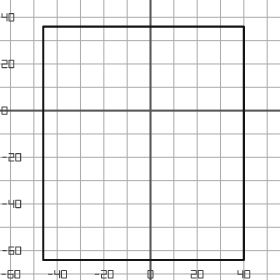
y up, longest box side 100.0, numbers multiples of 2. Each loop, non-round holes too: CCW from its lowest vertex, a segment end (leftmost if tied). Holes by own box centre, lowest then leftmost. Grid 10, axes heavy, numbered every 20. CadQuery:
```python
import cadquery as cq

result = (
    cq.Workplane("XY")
    .moveTo(-46.0, -64.0)
    .lineTo(40.0, -64.0)
    .lineTo(40.0, 36.0)
    .lineTo(-46.0, 36.0)
    .close()
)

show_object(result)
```